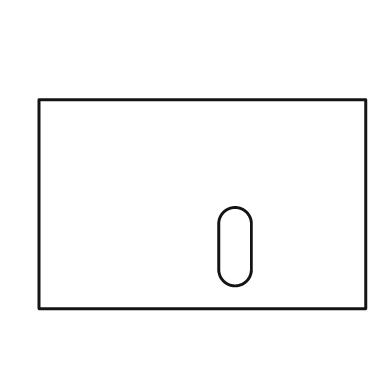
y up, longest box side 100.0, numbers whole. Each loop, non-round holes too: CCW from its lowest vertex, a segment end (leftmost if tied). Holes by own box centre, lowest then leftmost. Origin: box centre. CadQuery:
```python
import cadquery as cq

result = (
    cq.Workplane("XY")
    .moveTo(-50.0, -32.0)
    .lineTo(50.0, -32.0)
    .lineTo(50.0, 32.0)
    .lineTo(-50.0, 32.0)
    .close()
    .moveTo(5.0, -20.0)
    .threePointArc((10.0, -25.0), (15.0, -20.0))
    .lineTo(15.0, -6.0)
    .threePointArc((10.0, -1.0), (5.0, -6.0))
    .close()
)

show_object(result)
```